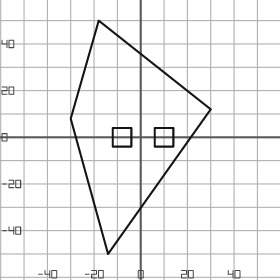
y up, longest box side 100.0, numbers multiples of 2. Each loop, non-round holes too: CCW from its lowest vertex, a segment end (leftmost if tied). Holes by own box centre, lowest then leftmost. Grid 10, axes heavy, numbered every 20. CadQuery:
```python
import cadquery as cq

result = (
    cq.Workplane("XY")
    .moveTo(-14.0, -50.0)
    .lineTo(30.0, 12.0)
    .lineTo(-18.0, 50.0)
    .lineTo(-30.0, 8.0)
    .close()
    .moveTo(-12.0, -4.0)
    .lineTo(-4.0, -4.0)
    .lineTo(-4.0, 4.0)
    .lineTo(-12.0, 4.0)
    .close()
    .moveTo(6.0, -4.0)
    .lineTo(14.0, -4.0)
    .lineTo(14.0, 4.0)
    .lineTo(6.0, 4.0)
    .close()
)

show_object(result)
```